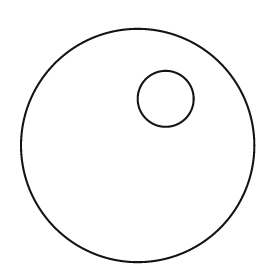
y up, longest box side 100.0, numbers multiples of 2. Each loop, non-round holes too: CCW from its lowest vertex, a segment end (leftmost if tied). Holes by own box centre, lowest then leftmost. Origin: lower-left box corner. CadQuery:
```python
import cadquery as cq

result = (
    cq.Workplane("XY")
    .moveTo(50.0, 50.0)
    .circle(50.0)
    .moveTo(62.0, 70.0)
    .circle(12.0)
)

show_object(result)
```